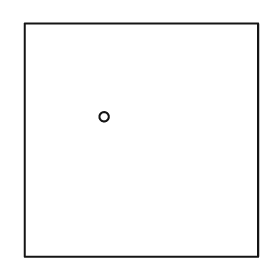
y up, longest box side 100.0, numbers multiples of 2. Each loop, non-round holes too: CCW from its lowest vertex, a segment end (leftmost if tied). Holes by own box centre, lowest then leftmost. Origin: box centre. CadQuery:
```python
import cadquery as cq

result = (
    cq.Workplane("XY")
    .moveTo(-50.0, -50.0)
    .lineTo(50.0, -50.0)
    .lineTo(50.0, 50.0)
    .lineTo(-50.0, 50.0)
    .close()
    .moveTo(-16.0, 10.0)
    .circle(2.0)
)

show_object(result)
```